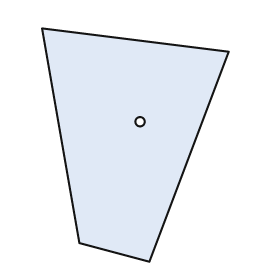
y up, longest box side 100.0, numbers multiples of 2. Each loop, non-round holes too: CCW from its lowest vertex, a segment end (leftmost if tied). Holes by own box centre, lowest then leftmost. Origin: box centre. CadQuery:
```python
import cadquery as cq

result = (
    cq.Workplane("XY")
    .moveTo(6.0, -50.0)
    .lineTo(40.0, 40.0)
    .lineTo(-40.0, 50.0)
    .lineTo(-24.0, -42.0)
    .close()
    .moveTo(2.0, 10.0)
    .circle(2.0)
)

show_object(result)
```